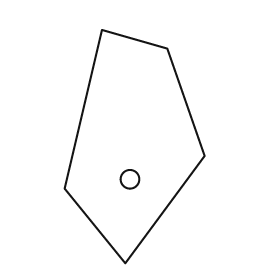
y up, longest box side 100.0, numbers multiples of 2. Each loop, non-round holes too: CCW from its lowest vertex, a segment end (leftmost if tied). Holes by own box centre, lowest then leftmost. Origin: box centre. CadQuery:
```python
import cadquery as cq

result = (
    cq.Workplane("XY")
    .moveTo(-4.0, -50.0)
    .lineTo(30.0, -4.0)
    .lineTo(14.0, 42.0)
    .lineTo(-14.0, 50.0)
    .lineTo(-30.0, -18.0)
    .close()
    .moveTo(-2.0, -14.0)
    .circle(4.0)
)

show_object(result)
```